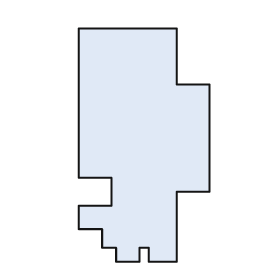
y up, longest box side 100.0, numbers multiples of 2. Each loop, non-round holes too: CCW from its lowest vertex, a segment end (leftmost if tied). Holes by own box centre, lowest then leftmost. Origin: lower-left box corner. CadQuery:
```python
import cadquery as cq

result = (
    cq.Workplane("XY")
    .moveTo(16.0, 0.0)
    .lineTo(26.0, 0.0)
    .lineTo(26.0, 6.0)
    .lineTo(30.0, 6.0)
    .lineTo(30.0, 0.0)
    .lineTo(42.0, 0.0)
    .lineTo(42.0, 30.0)
    .lineTo(56.0, 30.0)
    .lineTo(56.0, 76.0)
    .lineTo(42.0, 76.0)
    .lineTo(42.0, 100.0)
    .lineTo(0.0, 100.0)
    .lineTo(0.0, 36.0)
    .lineTo(14.0, 36.0)
    .lineTo(14.0, 24.0)
    .lineTo(0.0, 24.0)
    .lineTo(0.0, 14.0)
    .lineTo(10.0, 14.0)
    .lineTo(10.0, 6.0)
    .lineTo(16.0, 6.0)
    .close()
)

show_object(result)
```